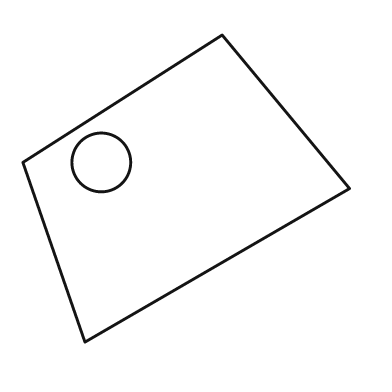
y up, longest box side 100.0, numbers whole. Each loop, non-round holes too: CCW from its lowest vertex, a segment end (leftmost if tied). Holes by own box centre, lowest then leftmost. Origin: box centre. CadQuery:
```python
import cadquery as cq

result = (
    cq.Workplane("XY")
    .moveTo(-31.0, -47.0)
    .lineTo(50.0, 0.0)
    .lineTo(11.0, 47.0)
    .lineTo(-50.0, 8.0)
    .close()
    .moveTo(-26.0, 8.0)
    .circle(9.0)
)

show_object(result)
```